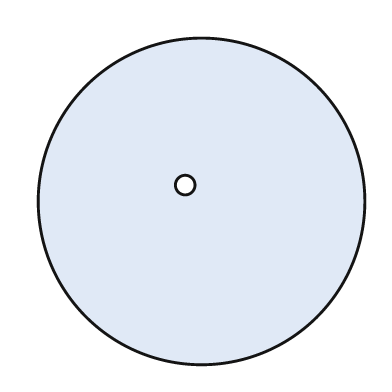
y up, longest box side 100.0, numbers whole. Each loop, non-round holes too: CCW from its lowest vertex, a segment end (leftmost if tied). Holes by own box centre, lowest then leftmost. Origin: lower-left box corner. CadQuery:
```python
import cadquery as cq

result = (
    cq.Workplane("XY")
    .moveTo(50.0, 50.0)
    .circle(50.0)
    .moveTo(45.0, 55.0)
    .circle(3.0)
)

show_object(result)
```